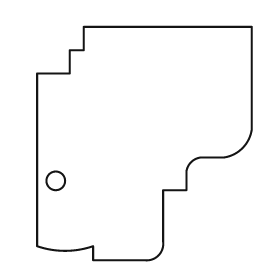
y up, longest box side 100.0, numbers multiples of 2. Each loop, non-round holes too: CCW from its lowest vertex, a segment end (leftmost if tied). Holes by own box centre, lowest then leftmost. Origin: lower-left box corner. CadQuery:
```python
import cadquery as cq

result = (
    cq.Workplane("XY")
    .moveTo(24.0, 0.0)
    .lineTo(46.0, 0.0)
    .threePointArc((52.0, 2.0), (54.0, 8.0))
    .lineTo(54.0, 30.0)
    .lineTo(64.0, 30.0)
    .lineTo(64.0, 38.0)
    .threePointArc((66.0, 42.0), (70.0, 44.0))
    .lineTo(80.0, 44.0)
    .threePointArc((88.0, 48.0), (92.0, 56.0))
    .lineTo(92.0, 100.0)
    .lineTo(20.0, 100.0)
    .lineTo(20.0, 90.0)
    .lineTo(14.0, 90.0)
    .lineTo(14.0, 80.0)
    .lineTo(0.0, 80.0)
    .lineTo(0.0, 6.0)
    .threePointArc((12.0, 4.0), (24.0, 6.0))
    .close()
    .moveTo(8.0, 34.0)
    .circle(4.0)
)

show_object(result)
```